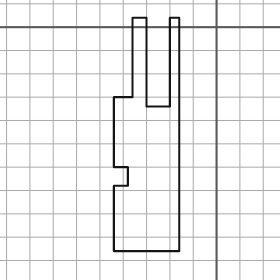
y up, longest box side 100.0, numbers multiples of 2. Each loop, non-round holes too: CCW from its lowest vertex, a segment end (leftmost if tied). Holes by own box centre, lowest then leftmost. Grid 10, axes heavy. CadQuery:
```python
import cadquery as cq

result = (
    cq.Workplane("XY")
    .moveTo(-44.0, -96.0)
    .lineTo(-16.0, -96.0)
    .lineTo(-16.0, 4.0)
    .lineTo(-20.0, 4.0)
    .lineTo(-20.0, -34.0)
    .lineTo(-30.0, -34.0)
    .lineTo(-30.0, 4.0)
    .lineTo(-36.0, 4.0)
    .lineTo(-36.0, -30.0)
    .lineTo(-44.0, -30.0)
    .lineTo(-44.0, -60.0)
    .lineTo(-38.0, -60.0)
    .lineTo(-38.0, -68.0)
    .lineTo(-44.0, -68.0)
    .close()
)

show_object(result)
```